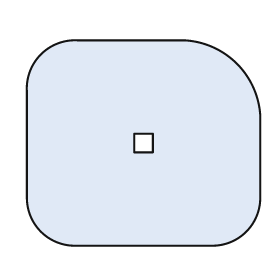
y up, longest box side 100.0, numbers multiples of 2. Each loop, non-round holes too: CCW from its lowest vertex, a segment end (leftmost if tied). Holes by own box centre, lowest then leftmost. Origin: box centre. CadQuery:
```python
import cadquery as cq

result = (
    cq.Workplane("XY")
    .moveTo(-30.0, -44.0)
    .lineTo(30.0, -44.0)
    .threePointArc((44.0, -38.0), (50.0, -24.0))
    .lineTo(50.0, 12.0)
    .threePointArc((40.0, 34.0), (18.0, 44.0))
    .lineTo(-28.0, 44.0)
    .threePointArc((-44.0, 38.0), (-50.0, 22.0))
    .lineTo(-50.0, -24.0)
    .threePointArc((-44.0, -38.0), (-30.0, -44.0))
    .close()
    .moveTo(-4.0, -4.0)
    .lineTo(4.0, -4.0)
    .lineTo(4.0, 4.0)
    .lineTo(-4.0, 4.0)
    .close()
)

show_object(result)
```